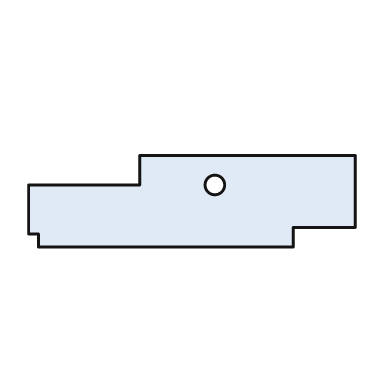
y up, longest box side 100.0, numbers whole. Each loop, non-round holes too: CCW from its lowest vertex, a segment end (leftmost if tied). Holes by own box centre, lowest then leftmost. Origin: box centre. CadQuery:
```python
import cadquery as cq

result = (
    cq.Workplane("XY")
    .moveTo(-47.0, -14.0)
    .lineTo(31.0, -14.0)
    .lineTo(31.0, -8.0)
    .lineTo(50.0, -8.0)
    .lineTo(50.0, 14.0)
    .lineTo(-16.0, 14.0)
    .lineTo(-16.0, 5.0)
    .lineTo(-50.0, 5.0)
    .lineTo(-50.0, -10.0)
    .lineTo(-47.0, -10.0)
    .close()
    .moveTo(7.0, 5.0)
    .circle(3.0)
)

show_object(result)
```